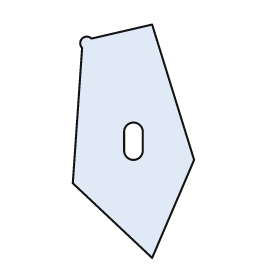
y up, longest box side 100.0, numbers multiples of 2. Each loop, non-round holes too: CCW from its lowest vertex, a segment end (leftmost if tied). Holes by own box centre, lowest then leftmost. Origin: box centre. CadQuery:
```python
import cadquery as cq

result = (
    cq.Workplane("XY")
    .moveTo(8.0, -50.0)
    .lineTo(26.0, -8.0)
    .lineTo(8.0, 50.0)
    .lineTo(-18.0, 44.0)
    .threePointArc((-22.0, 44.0), (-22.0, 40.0))
    .lineTo(-26.0, -18.0)
    .close()
    .moveTo(-4.0, -4.0)
    .threePointArc((0.0, -8.0), (4.0, -4.0))
    .lineTo(4.0, 4.0)
    .threePointArc((0.0, 8.0), (-4.0, 4.0))
    .close()
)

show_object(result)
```